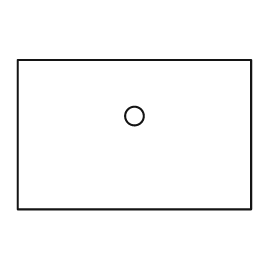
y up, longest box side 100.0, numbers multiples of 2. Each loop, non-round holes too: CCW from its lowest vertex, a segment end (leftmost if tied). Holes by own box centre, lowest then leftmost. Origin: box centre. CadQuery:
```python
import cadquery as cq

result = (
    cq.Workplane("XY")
    .moveTo(-50.0, -32.0)
    .lineTo(50.0, -32.0)
    .lineTo(50.0, 32.0)
    .lineTo(-50.0, 32.0)
    .close()
    .moveTo(0.0, 8.0)
    .circle(4.0)
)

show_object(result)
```